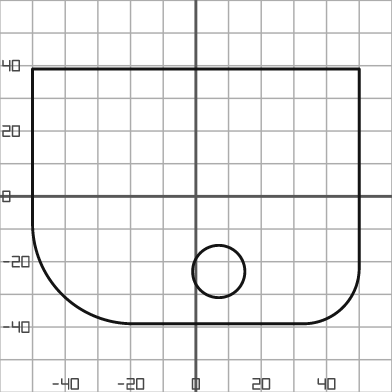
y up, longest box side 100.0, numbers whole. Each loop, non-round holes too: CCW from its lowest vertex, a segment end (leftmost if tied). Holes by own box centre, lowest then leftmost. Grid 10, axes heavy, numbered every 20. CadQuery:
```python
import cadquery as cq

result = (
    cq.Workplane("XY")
    .moveTo(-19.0, -39.0)
    .lineTo(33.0, -39.0)
    .threePointArc((45.0, -34.0), (50.0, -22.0))
    .lineTo(50.0, 39.0)
    .lineTo(-50.0, 39.0)
    .lineTo(-50.0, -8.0)
    .threePointArc((-41.0, -30.0), (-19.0, -39.0))
    .close()
    .moveTo(7.0, -23.0)
    .circle(8.0)
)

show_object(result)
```